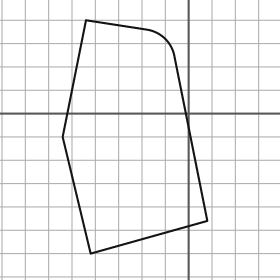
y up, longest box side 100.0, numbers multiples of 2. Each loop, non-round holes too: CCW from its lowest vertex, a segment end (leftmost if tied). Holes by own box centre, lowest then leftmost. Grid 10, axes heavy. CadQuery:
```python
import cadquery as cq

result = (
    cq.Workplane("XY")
    .moveTo(-42.0, -60.0)
    .lineTo(8.0, -46.0)
    .lineTo(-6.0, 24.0)
    .threePointArc((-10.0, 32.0), (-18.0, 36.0))
    .lineTo(-44.0, 40.0)
    .lineTo(-54.0, -10.0)
    .close()
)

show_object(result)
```